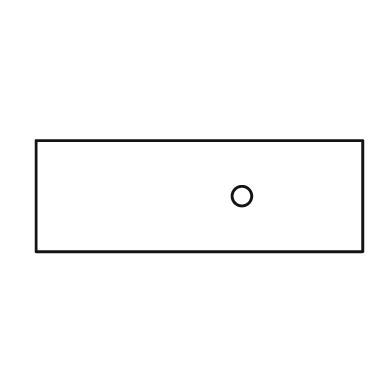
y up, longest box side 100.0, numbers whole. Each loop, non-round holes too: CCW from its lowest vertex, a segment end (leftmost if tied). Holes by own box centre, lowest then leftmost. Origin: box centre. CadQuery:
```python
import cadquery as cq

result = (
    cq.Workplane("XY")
    .moveTo(-50.0, -17.0)
    .lineTo(50.0, -17.0)
    .lineTo(50.0, 17.0)
    .lineTo(-50.0, 17.0)
    .close()
    .moveTo(13.0, 0.0)
    .circle(3.0)
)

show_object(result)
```